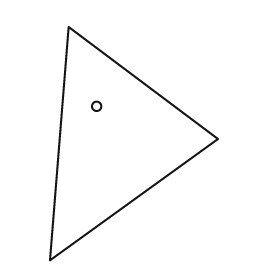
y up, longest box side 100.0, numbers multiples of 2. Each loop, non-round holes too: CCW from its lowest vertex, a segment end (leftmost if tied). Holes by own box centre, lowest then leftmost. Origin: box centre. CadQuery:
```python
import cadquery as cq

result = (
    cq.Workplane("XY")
    .moveTo(-36.0, -50.0)
    .lineTo(36.0, 2.0)
    .lineTo(-28.0, 50.0)
    .close()
    .moveTo(-16.0, 16.0)
    .circle(2.0)
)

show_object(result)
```